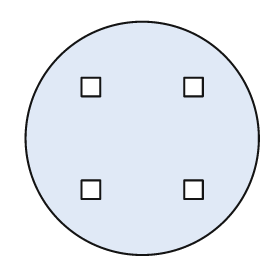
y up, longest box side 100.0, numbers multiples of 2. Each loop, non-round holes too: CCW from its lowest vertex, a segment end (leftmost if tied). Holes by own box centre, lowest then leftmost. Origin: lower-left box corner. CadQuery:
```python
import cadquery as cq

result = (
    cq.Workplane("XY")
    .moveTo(50.0, 50.0)
    .circle(50.0)
    .moveTo(24.0, 24.0)
    .lineTo(32.0, 24.0)
    .lineTo(32.0, 32.0)
    .lineTo(24.0, 32.0)
    .close()
    .moveTo(68.0, 24.0)
    .lineTo(76.0, 24.0)
    .lineTo(76.0, 32.0)
    .lineTo(68.0, 32.0)
    .close()
    .moveTo(24.0, 68.0)
    .lineTo(32.0, 68.0)
    .lineTo(32.0, 76.0)
    .lineTo(24.0, 76.0)
    .close()
    .moveTo(68.0, 68.0)
    .lineTo(76.0, 68.0)
    .lineTo(76.0, 76.0)
    .lineTo(68.0, 76.0)
    .close()
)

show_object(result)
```